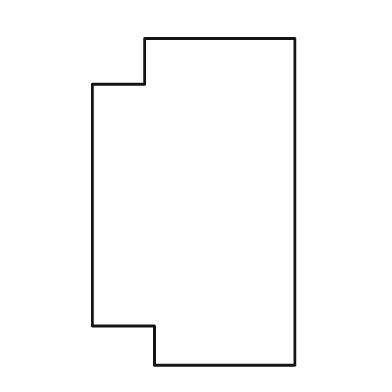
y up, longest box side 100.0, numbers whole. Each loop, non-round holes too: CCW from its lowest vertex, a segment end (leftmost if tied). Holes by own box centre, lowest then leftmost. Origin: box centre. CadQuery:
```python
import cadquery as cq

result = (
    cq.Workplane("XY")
    .moveTo(-12.0, -50.0)
    .lineTo(31.0, -50.0)
    .lineTo(31.0, 50.0)
    .lineTo(-15.0, 50.0)
    .lineTo(-15.0, 36.0)
    .lineTo(-31.0, 36.0)
    .lineTo(-31.0, -38.0)
    .lineTo(-12.0, -38.0)
    .close()
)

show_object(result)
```